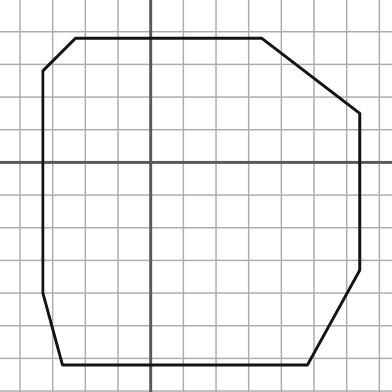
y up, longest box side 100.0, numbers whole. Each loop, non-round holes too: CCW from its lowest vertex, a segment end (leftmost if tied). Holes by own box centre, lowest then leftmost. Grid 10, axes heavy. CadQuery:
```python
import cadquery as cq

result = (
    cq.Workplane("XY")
    .moveTo(-27.0, -62.0)
    .lineTo(48.0, -62.0)
    .lineTo(64.0, -33.0)
    .lineTo(64.0, 15.0)
    .lineTo(34.0, 38.0)
    .lineTo(-23.0, 38.0)
    .lineTo(-33.0, 28.0)
    .lineTo(-33.0, -40.0)
    .close()
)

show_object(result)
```